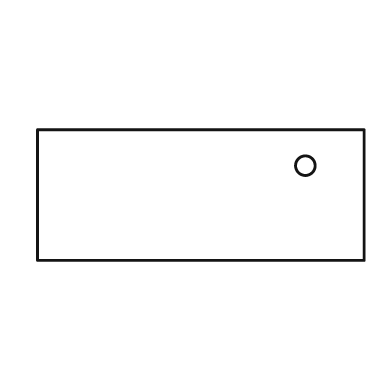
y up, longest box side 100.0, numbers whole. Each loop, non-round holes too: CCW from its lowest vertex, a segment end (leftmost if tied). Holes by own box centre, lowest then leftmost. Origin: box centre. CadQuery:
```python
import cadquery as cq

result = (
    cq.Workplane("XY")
    .moveTo(-50.0, -20.0)
    .lineTo(50.0, -20.0)
    .lineTo(50.0, 20.0)
    .lineTo(-50.0, 20.0)
    .close()
    .moveTo(32.0, 9.0)
    .circle(3.0)
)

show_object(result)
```